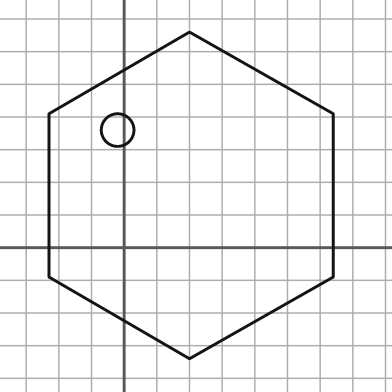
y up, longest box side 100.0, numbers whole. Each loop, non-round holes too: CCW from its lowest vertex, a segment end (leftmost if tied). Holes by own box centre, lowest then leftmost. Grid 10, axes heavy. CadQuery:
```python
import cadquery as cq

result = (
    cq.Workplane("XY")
    .moveTo(20.0, -34.0)
    .lineTo(64.0, -9.0)
    .lineTo(64.0, 41.0)
    .lineTo(20.0, 66.0)
    .lineTo(-23.0, 41.0)
    .lineTo(-23.0, -9.0)
    .close()
    .moveTo(-2.0, 36.0)
    .circle(5.0)
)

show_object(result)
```